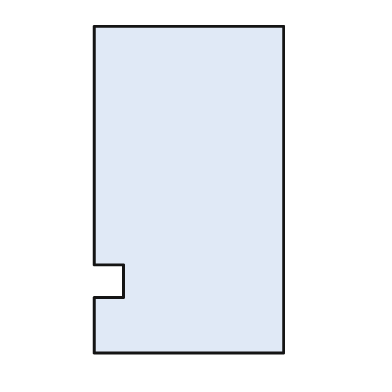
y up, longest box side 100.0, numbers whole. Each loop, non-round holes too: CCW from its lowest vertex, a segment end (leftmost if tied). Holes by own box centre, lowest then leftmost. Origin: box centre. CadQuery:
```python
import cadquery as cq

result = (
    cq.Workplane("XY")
    .moveTo(-29.0, -50.0)
    .lineTo(29.0, -50.0)
    .lineTo(29.0, 50.0)
    .lineTo(-29.0, 50.0)
    .lineTo(-29.0, -23.0)
    .lineTo(-20.0, -23.0)
    .lineTo(-20.0, -33.0)
    .lineTo(-29.0, -33.0)
    .close()
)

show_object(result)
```